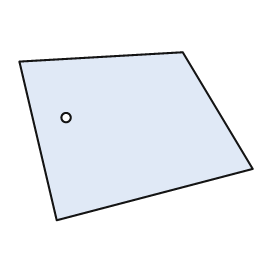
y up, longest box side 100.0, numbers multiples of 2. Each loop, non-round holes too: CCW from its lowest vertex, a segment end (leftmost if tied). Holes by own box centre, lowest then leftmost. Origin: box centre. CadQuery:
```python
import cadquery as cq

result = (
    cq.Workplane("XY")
    .moveTo(-34.0, -36.0)
    .lineTo(50.0, -14.0)
    .lineTo(20.0, 36.0)
    .lineTo(-50.0, 32.0)
    .close()
    .moveTo(-30.0, 8.0)
    .circle(2.0)
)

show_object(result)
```